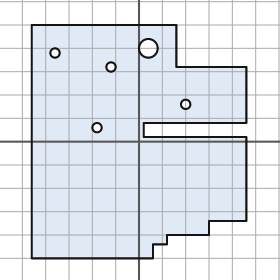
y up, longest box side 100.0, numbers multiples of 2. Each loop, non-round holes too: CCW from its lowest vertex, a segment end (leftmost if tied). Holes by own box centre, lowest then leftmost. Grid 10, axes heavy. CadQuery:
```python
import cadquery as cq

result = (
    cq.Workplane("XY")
    .moveTo(-46.0, -50.0)
    .lineTo(6.0, -50.0)
    .lineTo(6.0, -44.0)
    .lineTo(12.0, -44.0)
    .lineTo(12.0, -40.0)
    .lineTo(30.0, -40.0)
    .lineTo(30.0, -34.0)
    .lineTo(46.0, -34.0)
    .lineTo(46.0, 2.0)
    .lineTo(2.0, 2.0)
    .lineTo(2.0, 8.0)
    .lineTo(46.0, 8.0)
    .lineTo(46.0, 32.0)
    .lineTo(16.0, 32.0)
    .lineTo(16.0, 50.0)
    .lineTo(-46.0, 50.0)
    .close()
    .moveTo(-18.0, 6.0)
    .circle(2.0)
    .moveTo(20.0, 16.0)
    .circle(2.0)
    .moveTo(-12.0, 32.0)
    .circle(2.0)
    .moveTo(-36.0, 38.0)
    .circle(2.0)
    .moveTo(4.0, 40.0)
    .circle(4.0)
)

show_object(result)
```